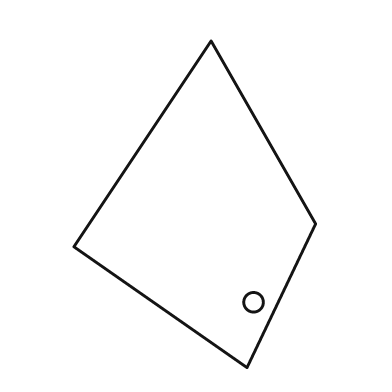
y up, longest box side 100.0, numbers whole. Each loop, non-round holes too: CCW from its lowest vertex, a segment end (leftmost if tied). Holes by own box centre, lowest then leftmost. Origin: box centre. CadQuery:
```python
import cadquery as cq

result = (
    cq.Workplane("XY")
    .moveTo(16.0, -50.0)
    .lineTo(37.0, -6.0)
    .lineTo(5.0, 50.0)
    .lineTo(-37.0, -13.0)
    .close()
    .moveTo(18.0, -30.0)
    .circle(3.0)
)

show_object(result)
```